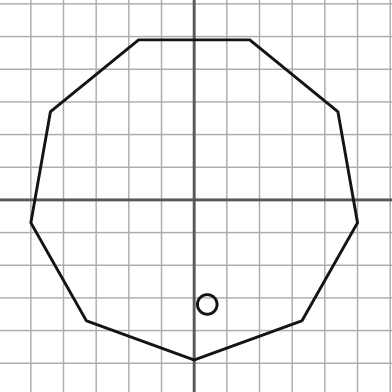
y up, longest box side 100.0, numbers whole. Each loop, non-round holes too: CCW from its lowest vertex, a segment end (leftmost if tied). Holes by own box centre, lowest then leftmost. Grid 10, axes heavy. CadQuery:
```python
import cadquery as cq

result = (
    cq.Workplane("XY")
    .moveTo(0.0, -49.0)
    .lineTo(33.0, -37.0)
    .lineTo(50.0, -7.0)
    .lineTo(44.0, 27.0)
    .lineTo(17.0, 49.0)
    .lineTo(-17.0, 49.0)
    .lineTo(-44.0, 27.0)
    .lineTo(-50.0, -7.0)
    .lineTo(-33.0, -37.0)
    .close()
    .moveTo(4.0, -32.0)
    .circle(3.0)
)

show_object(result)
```